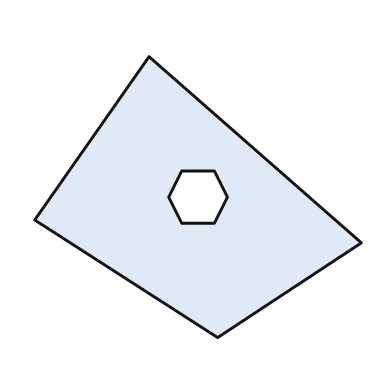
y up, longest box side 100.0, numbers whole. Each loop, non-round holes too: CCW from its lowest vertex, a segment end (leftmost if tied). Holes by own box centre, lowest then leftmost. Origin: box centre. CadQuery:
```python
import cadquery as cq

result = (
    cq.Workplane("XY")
    .moveTo(6.0, -43.0)
    .lineTo(50.0, -14.0)
    .lineTo(-15.0, 43.0)
    .lineTo(-50.0, -7.0)
    .close()
    .moveTo(-5.0, -8.0)
    .lineTo(5.0, -8.0)
    .lineTo(9.0, 0.0)
    .lineTo(5.0, 8.0)
    .lineTo(-5.0, 8.0)
    .lineTo(-9.0, 0.0)
    .close()
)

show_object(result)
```